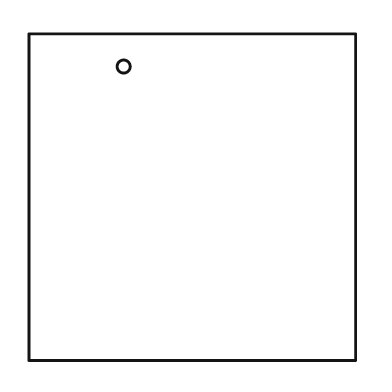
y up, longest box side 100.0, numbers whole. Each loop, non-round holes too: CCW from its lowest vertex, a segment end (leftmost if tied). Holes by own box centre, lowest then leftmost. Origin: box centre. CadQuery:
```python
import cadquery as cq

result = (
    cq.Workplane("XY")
    .moveTo(-50.0, -50.0)
    .lineTo(50.0, -50.0)
    .lineTo(50.0, 50.0)
    .lineTo(-50.0, 50.0)
    .close()
    .moveTo(-21.0, 40.0)
    .circle(2.0)
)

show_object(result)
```